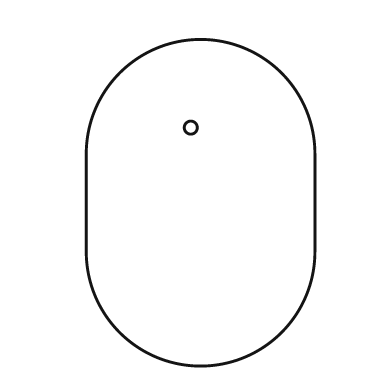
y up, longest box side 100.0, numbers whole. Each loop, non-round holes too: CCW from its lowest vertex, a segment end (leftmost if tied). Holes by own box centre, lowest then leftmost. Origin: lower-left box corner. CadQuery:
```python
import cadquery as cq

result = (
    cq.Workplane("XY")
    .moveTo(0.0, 35.0)
    .threePointArc((35.0, 0.0), (70.0, 35.0))
    .lineTo(70.0, 65.0)
    .threePointArc((35.0, 100.0), (0.0, 65.0))
    .close()
    .moveTo(32.0, 73.0)
    .circle(2.0)
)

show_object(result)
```